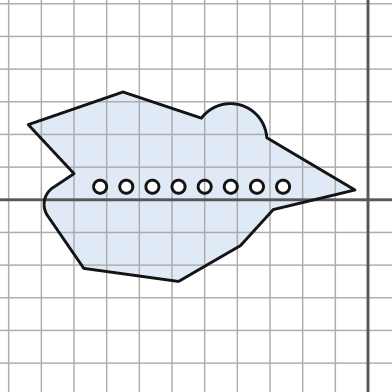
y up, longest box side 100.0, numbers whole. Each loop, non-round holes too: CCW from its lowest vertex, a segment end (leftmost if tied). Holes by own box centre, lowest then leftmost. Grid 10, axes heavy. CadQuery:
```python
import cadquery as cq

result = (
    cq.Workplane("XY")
    .moveTo(-58.0, -25.0)
    .lineTo(-39.0, -14.0)
    .lineTo(-29.0, -3.0)
    .lineTo(-4.0, 3.0)
    .lineTo(-31.0, 19.0)
    .threePointArc((-39.0, 29.0), (-51.0, 25.0))
    .lineTo(-75.0, 33.0)
    .lineTo(-104.0, 23.0)
    .lineTo(-90.0, 8.0)
    .lineTo(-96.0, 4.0)
    .threePointArc((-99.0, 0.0), (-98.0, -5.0))
    .lineTo(-87.0, -21.0)
    .close()
    .moveTo(-82.0, 4.0)
    .circle(2.0)
    .moveTo(-74.0, 4.0)
    .circle(2.0)
    .moveTo(-66.0, 4.0)
    .circle(2.0)
    .moveTo(-58.0, 4.0)
    .circle(2.0)
    .moveTo(-50.0, 4.0)
    .circle(2.0)
    .moveTo(-42.0, 4.0)
    .circle(2.0)
    .moveTo(-34.0, 4.0)
    .circle(2.0)
    .moveTo(-26.0, 4.0)
    .circle(2.0)
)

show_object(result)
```